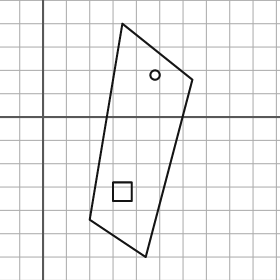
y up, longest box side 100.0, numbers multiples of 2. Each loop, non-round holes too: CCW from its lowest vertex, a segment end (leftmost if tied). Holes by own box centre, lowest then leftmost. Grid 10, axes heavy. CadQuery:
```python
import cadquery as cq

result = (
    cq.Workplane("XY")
    .moveTo(44.0, -60.0)
    .lineTo(64.0, 16.0)
    .lineTo(34.0, 40.0)
    .lineTo(20.0, -44.0)
    .close()
    .moveTo(30.0, -36.0)
    .lineTo(38.0, -36.0)
    .lineTo(38.0, -28.0)
    .lineTo(30.0, -28.0)
    .close()
    .moveTo(48.0, 18.0)
    .circle(2.0)
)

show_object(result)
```